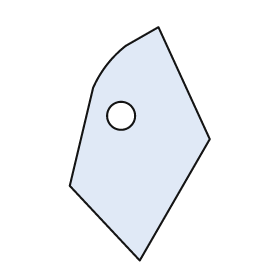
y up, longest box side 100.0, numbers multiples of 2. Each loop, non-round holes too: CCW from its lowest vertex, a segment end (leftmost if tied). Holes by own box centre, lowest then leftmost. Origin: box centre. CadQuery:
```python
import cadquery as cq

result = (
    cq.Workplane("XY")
    .moveTo(0.0, -50.0)
    .lineTo(30.0, 2.0)
    .lineTo(8.0, 50.0)
    .lineTo(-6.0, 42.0)
    .threePointArc((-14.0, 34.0), (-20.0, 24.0))
    .lineTo(-30.0, -18.0)
    .close()
    .moveTo(-8.0, 12.0)
    .circle(6.0)
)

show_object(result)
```